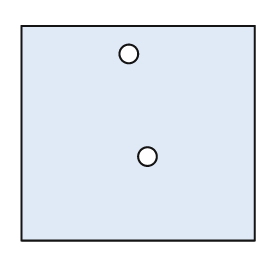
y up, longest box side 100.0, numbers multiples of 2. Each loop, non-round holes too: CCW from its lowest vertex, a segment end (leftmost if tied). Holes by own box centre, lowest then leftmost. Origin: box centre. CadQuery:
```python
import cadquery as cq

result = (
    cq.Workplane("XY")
    .moveTo(-50.0, -46.0)
    .lineTo(50.0, -46.0)
    .lineTo(50.0, 46.0)
    .lineTo(-50.0, 46.0)
    .close()
    .moveTo(4.0, -10.0)
    .circle(4.0)
    .moveTo(-4.0, 34.0)
    .circle(4.0)
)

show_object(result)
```